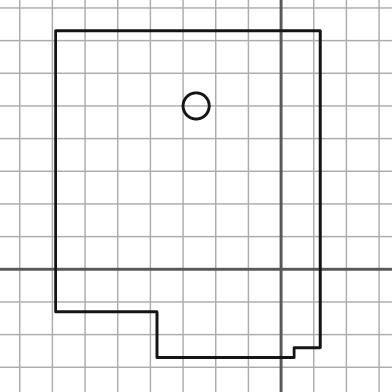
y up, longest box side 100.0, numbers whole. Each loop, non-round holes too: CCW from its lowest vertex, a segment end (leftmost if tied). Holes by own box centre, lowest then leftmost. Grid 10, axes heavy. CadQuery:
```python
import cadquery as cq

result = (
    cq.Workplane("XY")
    .moveTo(-38.0, -27.0)
    .lineTo(4.0, -27.0)
    .lineTo(4.0, -24.0)
    .lineTo(12.0, -24.0)
    .lineTo(12.0, 73.0)
    .lineTo(-69.0, 73.0)
    .lineTo(-69.0, -13.0)
    .lineTo(-38.0, -13.0)
    .close()
    .moveTo(-26.0, 50.0)
    .circle(4.0)
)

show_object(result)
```